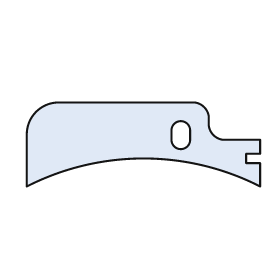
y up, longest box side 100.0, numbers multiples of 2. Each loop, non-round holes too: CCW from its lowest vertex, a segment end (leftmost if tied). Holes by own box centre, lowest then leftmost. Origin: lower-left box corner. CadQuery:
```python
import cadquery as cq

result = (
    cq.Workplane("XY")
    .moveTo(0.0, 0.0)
    .threePointArc((50.0, 12.0), (100.0, 0.0))
    .lineTo(100.0, 10.0)
    .lineTo(94.0, 10.0)
    .lineTo(94.0, 14.0)
    .lineTo(100.0, 14.0)
    .lineTo(100.0, 20.0)
    .lineTo(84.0, 20.0)
    .threePointArc((80.0, 22.0), (78.0, 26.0))
    .lineTo(78.0, 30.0)
    .threePointArc((76.0, 34.0), (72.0, 36.0))
    .lineTo(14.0, 36.0)
    .threePointArc((4.0, 32.0), (0.0, 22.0))
    .close()
    .moveTo(62.0, 20.0)
    .threePointArc((66.0, 16.0), (70.0, 20.0))
    .lineTo(70.0, 24.0)
    .threePointArc((66.0, 28.0), (62.0, 24.0))
    .close()
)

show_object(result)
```